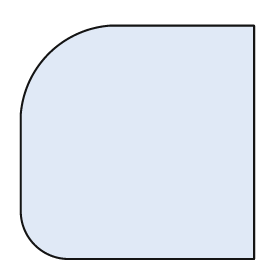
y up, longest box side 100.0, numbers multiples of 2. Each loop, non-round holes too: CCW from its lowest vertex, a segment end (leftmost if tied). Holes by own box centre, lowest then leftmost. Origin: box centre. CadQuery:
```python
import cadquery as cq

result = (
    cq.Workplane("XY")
    .moveTo(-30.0, -50.0)
    .lineTo(50.0, -50.0)
    .lineTo(50.0, 50.0)
    .lineTo(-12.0, 50.0)
    .threePointArc((-38.0, 38.0), (-50.0, 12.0))
    .lineTo(-50.0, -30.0)
    .threePointArc((-44.0, -44.0), (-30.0, -50.0))
    .close()
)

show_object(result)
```